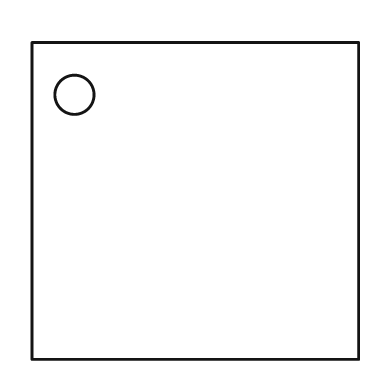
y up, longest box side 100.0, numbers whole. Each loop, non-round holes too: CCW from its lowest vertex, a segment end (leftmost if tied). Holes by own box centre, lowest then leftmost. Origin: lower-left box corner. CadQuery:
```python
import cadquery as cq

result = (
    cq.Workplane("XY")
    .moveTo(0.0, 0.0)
    .lineTo(100.0, 0.0)
    .lineTo(100.0, 97.0)
    .lineTo(0.0, 97.0)
    .close()
    .moveTo(13.0, 81.0)
    .circle(6.0)
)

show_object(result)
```